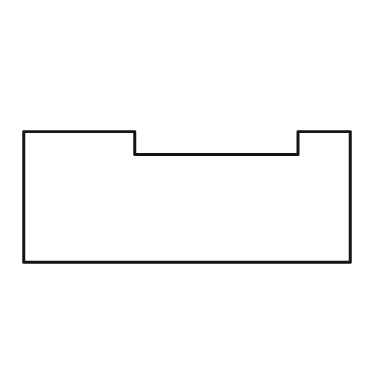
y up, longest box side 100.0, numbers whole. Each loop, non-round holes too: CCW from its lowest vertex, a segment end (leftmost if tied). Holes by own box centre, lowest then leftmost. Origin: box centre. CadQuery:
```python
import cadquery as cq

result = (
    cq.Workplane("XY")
    .moveTo(-50.0, -20.0)
    .lineTo(50.0, -20.0)
    .lineTo(50.0, 20.0)
    .lineTo(34.0, 20.0)
    .lineTo(34.0, 13.0)
    .lineTo(-16.0, 13.0)
    .lineTo(-16.0, 20.0)
    .lineTo(-50.0, 20.0)
    .close()
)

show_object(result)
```